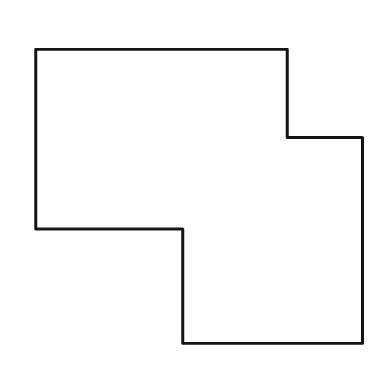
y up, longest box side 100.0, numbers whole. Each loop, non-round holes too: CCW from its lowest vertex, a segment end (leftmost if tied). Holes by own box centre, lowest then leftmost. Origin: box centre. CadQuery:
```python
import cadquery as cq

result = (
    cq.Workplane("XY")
    .moveTo(-5.0, -45.0)
    .lineTo(50.0, -45.0)
    .lineTo(50.0, 18.0)
    .lineTo(27.0, 18.0)
    .lineTo(27.0, 45.0)
    .lineTo(-50.0, 45.0)
    .lineTo(-50.0, -10.0)
    .lineTo(-5.0, -10.0)
    .close()
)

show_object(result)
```